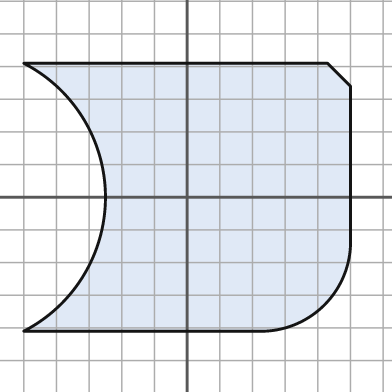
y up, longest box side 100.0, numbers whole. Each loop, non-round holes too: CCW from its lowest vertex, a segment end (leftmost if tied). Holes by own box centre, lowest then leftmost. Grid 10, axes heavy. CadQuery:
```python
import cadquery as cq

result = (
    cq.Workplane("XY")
    .moveTo(-50.0, -41.0)
    .lineTo(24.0, -41.0)
    .threePointArc((42.0, -33.0), (50.0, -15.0))
    .lineTo(50.0, 34.0)
    .lineTo(43.0, 41.0)
    .lineTo(-50.0, 41.0)
    .threePointArc((-25.0, 0.0), (-50.0, -41.0))
    .close()
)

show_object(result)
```